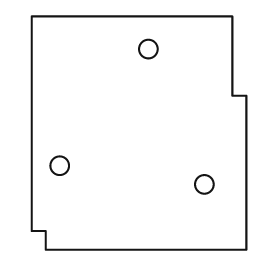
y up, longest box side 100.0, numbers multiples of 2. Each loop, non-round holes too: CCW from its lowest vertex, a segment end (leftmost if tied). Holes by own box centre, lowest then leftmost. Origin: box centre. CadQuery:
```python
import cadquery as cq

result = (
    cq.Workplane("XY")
    .moveTo(-40.0, -50.0)
    .lineTo(46.0, -50.0)
    .lineTo(46.0, 16.0)
    .lineTo(40.0, 16.0)
    .lineTo(40.0, 50.0)
    .lineTo(-46.0, 50.0)
    .lineTo(-46.0, -42.0)
    .lineTo(-40.0, -42.0)
    .close()
    .moveTo(28.0, -22.0)
    .circle(4.0)
    .moveTo(-34.0, -14.0)
    .circle(4.0)
    .moveTo(4.0, 36.0)
    .circle(4.0)
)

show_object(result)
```